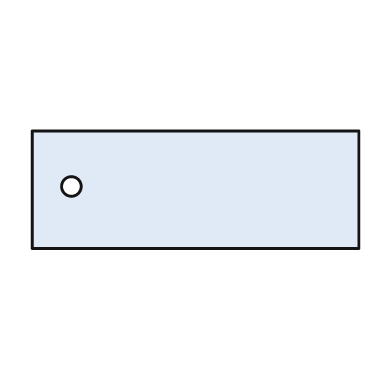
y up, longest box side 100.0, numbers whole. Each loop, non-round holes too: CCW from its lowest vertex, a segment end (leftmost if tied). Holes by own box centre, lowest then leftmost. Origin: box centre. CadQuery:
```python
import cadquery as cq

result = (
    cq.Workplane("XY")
    .moveTo(-50.0, -18.0)
    .lineTo(50.0, -18.0)
    .lineTo(50.0, 18.0)
    .lineTo(-50.0, 18.0)
    .close()
    .moveTo(-38.0, 1.0)
    .circle(3.0)
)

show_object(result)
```